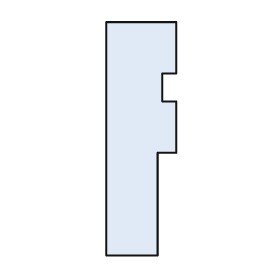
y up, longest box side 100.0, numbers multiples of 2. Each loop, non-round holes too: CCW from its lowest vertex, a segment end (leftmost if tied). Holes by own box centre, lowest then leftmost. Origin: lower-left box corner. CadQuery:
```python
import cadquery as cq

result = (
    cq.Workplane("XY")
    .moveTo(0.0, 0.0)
    .lineTo(22.0, 0.0)
    .lineTo(22.0, 44.0)
    .lineTo(30.0, 44.0)
    .lineTo(30.0, 66.0)
    .lineTo(24.0, 66.0)
    .lineTo(24.0, 78.0)
    .lineTo(30.0, 78.0)
    .lineTo(30.0, 100.0)
    .lineTo(0.0, 100.0)
    .close()
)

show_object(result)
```